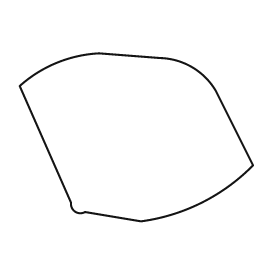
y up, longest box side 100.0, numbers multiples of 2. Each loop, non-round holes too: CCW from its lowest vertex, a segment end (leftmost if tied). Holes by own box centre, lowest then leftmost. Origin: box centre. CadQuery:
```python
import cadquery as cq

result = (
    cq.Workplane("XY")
    .moveTo(2.0, -36.0)
    .threePointArc((28.0, -28.0), (50.0, -12.0))
    .lineTo(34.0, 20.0)
    .threePointArc((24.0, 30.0), (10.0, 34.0))
    .lineTo(-16.0, 36.0)
    .threePointArc((-34.0, 32.0), (-50.0, 22.0))
    .lineTo(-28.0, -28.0)
    .threePointArc((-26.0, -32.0), (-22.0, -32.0))
    .close()
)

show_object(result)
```